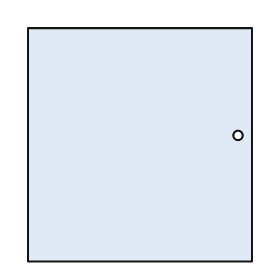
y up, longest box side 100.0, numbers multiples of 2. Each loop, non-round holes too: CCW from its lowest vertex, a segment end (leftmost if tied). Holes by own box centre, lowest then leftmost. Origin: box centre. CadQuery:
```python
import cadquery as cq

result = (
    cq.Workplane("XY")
    .moveTo(-48.0, -50.0)
    .lineTo(48.0, -50.0)
    .lineTo(48.0, 50.0)
    .lineTo(-48.0, 50.0)
    .close()
    .moveTo(42.0, 4.0)
    .circle(2.0)
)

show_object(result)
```